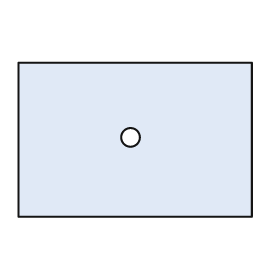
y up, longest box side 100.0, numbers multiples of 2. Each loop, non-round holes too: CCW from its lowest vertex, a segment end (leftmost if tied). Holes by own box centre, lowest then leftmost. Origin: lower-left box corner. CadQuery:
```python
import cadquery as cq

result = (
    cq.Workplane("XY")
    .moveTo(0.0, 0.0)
    .lineTo(100.0, 0.0)
    .lineTo(100.0, 66.0)
    .lineTo(0.0, 66.0)
    .close()
    .moveTo(48.0, 34.0)
    .circle(4.0)
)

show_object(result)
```